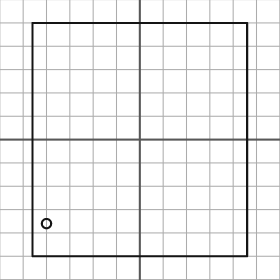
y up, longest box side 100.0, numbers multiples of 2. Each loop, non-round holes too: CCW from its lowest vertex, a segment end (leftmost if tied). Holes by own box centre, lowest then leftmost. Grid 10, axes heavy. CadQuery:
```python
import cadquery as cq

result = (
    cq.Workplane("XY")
    .moveTo(-46.0, -50.0)
    .lineTo(46.0, -50.0)
    .lineTo(46.0, 50.0)
    .lineTo(-46.0, 50.0)
    .close()
    .moveTo(-40.0, -36.0)
    .circle(2.0)
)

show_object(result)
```